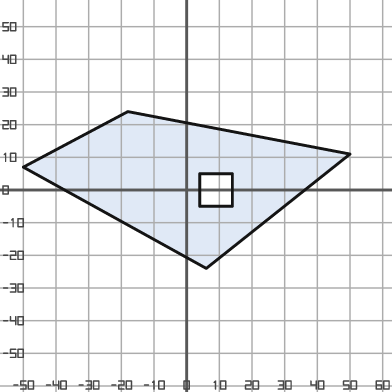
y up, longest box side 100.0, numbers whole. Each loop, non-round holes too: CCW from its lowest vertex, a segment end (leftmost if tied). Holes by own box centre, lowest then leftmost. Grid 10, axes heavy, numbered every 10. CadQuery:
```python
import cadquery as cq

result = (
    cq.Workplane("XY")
    .moveTo(6.0, -24.0)
    .lineTo(50.0, 11.0)
    .lineTo(-18.0, 24.0)
    .lineTo(-50.0, 7.0)
    .close()
    .moveTo(4.0, -5.0)
    .lineTo(14.0, -5.0)
    .lineTo(14.0, 5.0)
    .lineTo(4.0, 5.0)
    .close()
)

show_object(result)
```